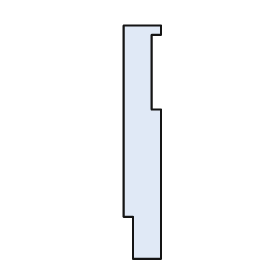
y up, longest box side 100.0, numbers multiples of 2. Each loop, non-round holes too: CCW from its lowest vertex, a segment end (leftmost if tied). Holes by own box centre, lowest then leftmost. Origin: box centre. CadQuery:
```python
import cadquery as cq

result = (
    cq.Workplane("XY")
    .moveTo(-4.0, -50.0)
    .lineTo(8.0, -50.0)
    .lineTo(8.0, 14.0)
    .lineTo(4.0, 14.0)
    .lineTo(4.0, 46.0)
    .lineTo(8.0, 46.0)
    .lineTo(8.0, 50.0)
    .lineTo(-8.0, 50.0)
    .lineTo(-8.0, -32.0)
    .lineTo(-4.0, -32.0)
    .close()
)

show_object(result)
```